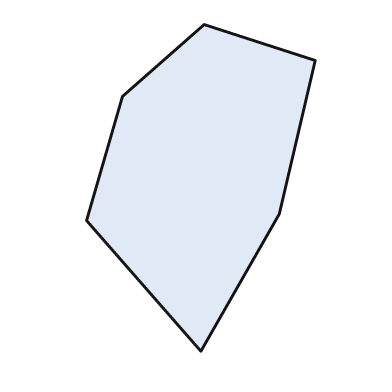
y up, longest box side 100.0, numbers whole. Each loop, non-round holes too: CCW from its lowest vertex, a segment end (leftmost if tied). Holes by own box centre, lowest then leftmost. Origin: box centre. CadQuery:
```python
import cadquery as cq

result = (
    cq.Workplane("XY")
    .moveTo(0.0, -50.0)
    .lineTo(24.0, -8.0)
    .lineTo(35.0, 39.0)
    .lineTo(1.0, 50.0)
    .lineTo(-24.0, 28.0)
    .lineTo(-35.0, -10.0)
    .close()
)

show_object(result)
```